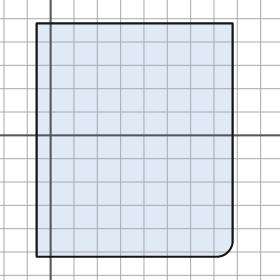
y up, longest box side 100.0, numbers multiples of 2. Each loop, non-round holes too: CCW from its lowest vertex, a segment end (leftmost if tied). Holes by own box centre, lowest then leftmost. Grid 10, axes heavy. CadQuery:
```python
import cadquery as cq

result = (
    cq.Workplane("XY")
    .moveTo(-6.0, -52.0)
    .lineTo(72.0, -52.0)
    .threePointArc((76.0, -50.0), (78.0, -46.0))
    .lineTo(78.0, 48.0)
    .lineTo(-6.0, 48.0)
    .close()
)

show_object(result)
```